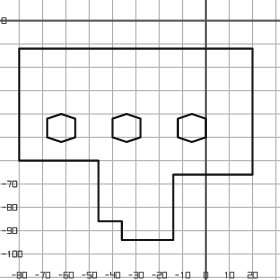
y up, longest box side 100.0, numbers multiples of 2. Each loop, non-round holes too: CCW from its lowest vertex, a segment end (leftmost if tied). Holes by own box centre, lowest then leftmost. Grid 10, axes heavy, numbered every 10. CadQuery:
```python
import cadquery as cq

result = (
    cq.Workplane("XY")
    .moveTo(-36.0, -94.0)
    .lineTo(-14.0, -94.0)
    .lineTo(-14.0, -66.0)
    .lineTo(20.0, -66.0)
    .lineTo(20.0, -12.0)
    .lineTo(-80.0, -12.0)
    .lineTo(-80.0, -60.0)
    .lineTo(-46.0, -60.0)
    .lineTo(-46.0, -86.0)
    .lineTo(-36.0, -86.0)
    .close()
    .moveTo(-62.0, -52.0)
    .lineTo(-56.0, -50.0)
    .lineTo(-56.0, -42.0)
    .lineTo(-62.0, -40.0)
    .lineTo(-68.0, -42.0)
    .lineTo(-68.0, -50.0)
    .close()
    .moveTo(-34.0, -52.0)
    .lineTo(-28.0, -50.0)
    .lineTo(-28.0, -42.0)
    .lineTo(-34.0, -40.0)
    .lineTo(-40.0, -42.0)
    .lineTo(-40.0, -50.0)
    .close()
    .moveTo(-6.0, -52.0)
    .lineTo(0.0, -50.0)
    .lineTo(0.0, -42.0)
    .lineTo(-6.0, -40.0)
    .lineTo(-12.0, -42.0)
    .lineTo(-12.0, -50.0)
    .close()
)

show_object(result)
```